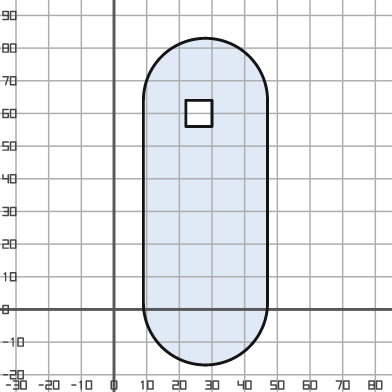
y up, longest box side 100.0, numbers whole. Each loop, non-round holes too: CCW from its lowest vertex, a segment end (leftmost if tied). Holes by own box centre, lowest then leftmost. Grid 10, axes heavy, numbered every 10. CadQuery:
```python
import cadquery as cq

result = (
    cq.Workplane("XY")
    .moveTo(9.0, 2.0)
    .threePointArc((28.0, -17.0), (47.0, 2.0))
    .lineTo(47.0, 64.0)
    .threePointArc((28.0, 83.0), (9.0, 64.0))
    .close()
    .moveTo(22.0, 56.0)
    .lineTo(30.0, 56.0)
    .lineTo(30.0, 64.0)
    .lineTo(22.0, 64.0)
    .close()
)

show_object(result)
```